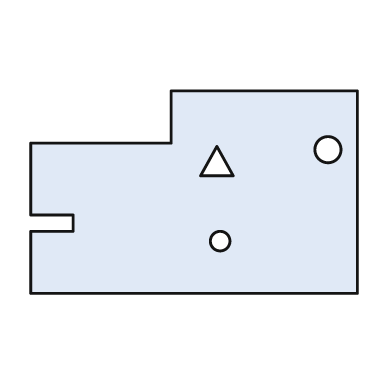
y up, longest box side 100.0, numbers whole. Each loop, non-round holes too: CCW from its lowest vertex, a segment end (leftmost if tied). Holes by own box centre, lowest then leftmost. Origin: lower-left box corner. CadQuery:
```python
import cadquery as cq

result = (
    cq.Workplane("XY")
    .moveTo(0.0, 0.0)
    .lineTo(100.0, 0.0)
    .lineTo(100.0, 62.0)
    .lineTo(43.0, 62.0)
    .lineTo(43.0, 46.0)
    .lineTo(0.0, 46.0)
    .lineTo(0.0, 24.0)
    .lineTo(13.0, 24.0)
    .lineTo(13.0, 19.0)
    .lineTo(0.0, 19.0)
    .close()
    .moveTo(58.0, 16.0)
    .circle(3.0)
    .moveTo(52.0, 36.0)
    .lineTo(62.0, 36.0)
    .lineTo(57.0, 45.0)
    .close()
    .moveTo(91.0, 44.0)
    .circle(4.0)
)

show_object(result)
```